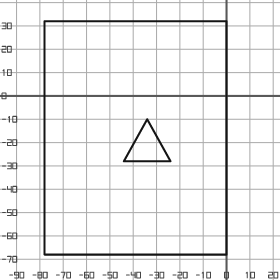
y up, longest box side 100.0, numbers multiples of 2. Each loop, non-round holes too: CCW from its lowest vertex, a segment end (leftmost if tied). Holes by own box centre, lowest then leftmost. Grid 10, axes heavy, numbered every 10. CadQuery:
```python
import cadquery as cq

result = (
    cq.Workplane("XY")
    .moveTo(-78.0, -68.0)
    .lineTo(0.0, -68.0)
    .lineTo(0.0, 32.0)
    .lineTo(-78.0, 32.0)
    .close()
    .moveTo(-44.0, -28.0)
    .lineTo(-24.0, -28.0)
    .lineTo(-34.0, -10.0)
    .close()
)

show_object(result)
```